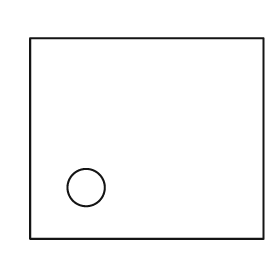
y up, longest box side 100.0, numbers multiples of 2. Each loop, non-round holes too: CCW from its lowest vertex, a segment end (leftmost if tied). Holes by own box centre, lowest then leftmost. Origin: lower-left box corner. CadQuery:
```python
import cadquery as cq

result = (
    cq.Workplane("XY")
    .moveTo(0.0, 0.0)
    .lineTo(100.0, 0.0)
    .lineTo(100.0, 86.0)
    .lineTo(0.0, 86.0)
    .close()
    .moveTo(24.0, 22.0)
    .circle(8.0)
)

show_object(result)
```